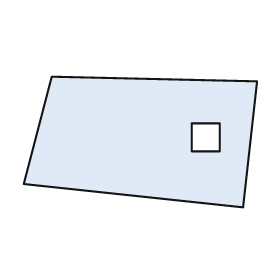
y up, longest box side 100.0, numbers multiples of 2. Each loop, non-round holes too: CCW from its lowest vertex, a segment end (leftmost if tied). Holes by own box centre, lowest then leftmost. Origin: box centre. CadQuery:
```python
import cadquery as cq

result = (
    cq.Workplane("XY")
    .moveTo(44.0, -28.0)
    .lineTo(50.0, 26.0)
    .lineTo(-38.0, 28.0)
    .lineTo(-50.0, -18.0)
    .close()
    .moveTo(22.0, -4.0)
    .lineTo(34.0, -4.0)
    .lineTo(34.0, 8.0)
    .lineTo(22.0, 8.0)
    .close()
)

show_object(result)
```